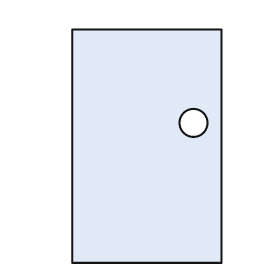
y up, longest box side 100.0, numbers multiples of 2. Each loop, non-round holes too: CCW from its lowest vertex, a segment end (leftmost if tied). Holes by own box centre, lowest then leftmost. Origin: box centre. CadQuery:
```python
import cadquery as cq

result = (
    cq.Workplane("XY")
    .moveTo(-32.0, -50.0)
    .lineTo(32.0, -50.0)
    .lineTo(32.0, 50.0)
    .lineTo(-32.0, 50.0)
    .close()
    .moveTo(20.0, 10.0)
    .circle(6.0)
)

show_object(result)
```